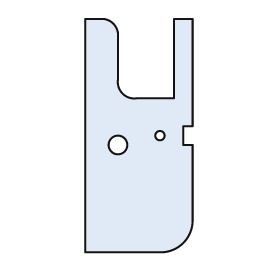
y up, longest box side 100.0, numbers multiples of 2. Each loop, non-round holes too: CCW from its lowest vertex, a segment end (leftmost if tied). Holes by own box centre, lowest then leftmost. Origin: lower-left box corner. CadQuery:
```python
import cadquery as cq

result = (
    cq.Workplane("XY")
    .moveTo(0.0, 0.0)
    .lineTo(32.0, 0.0)
    .threePointArc((42.0, 4.0), (46.0, 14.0))
    .lineTo(46.0, 46.0)
    .lineTo(42.0, 46.0)
    .lineTo(42.0, 54.0)
    .lineTo(46.0, 54.0)
    .lineTo(46.0, 100.0)
    .lineTo(38.0, 100.0)
    .lineTo(38.0, 66.0)
    .lineTo(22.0, 66.0)
    .threePointArc((16.0, 68.0), (14.0, 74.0))
    .lineTo(14.0, 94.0)
    .threePointArc((12.0, 98.0), (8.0, 100.0))
    .lineTo(0.0, 100.0)
    .close()
    .moveTo(14.0, 46.0)
    .circle(4.0)
    .moveTo(32.0, 50.0)
    .circle(2.0)
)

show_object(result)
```